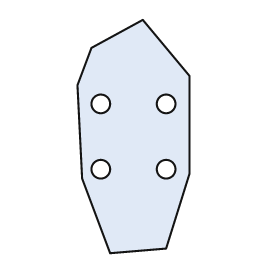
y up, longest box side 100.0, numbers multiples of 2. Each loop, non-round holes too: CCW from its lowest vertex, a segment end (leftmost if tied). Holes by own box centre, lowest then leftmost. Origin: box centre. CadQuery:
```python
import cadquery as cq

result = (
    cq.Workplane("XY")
    .moveTo(-10.0, -50.0)
    .lineTo(14.0, -48.0)
    .lineTo(24.0, -16.0)
    .lineTo(24.0, 26.0)
    .lineTo(4.0, 50.0)
    .lineTo(-18.0, 38.0)
    .lineTo(-24.0, 22.0)
    .lineTo(-22.0, -18.0)
    .close()
    .moveTo(-14.0, -14.0)
    .circle(4.0)
    .moveTo(14.0, -14.0)
    .circle(4.0)
    .moveTo(-14.0, 14.0)
    .circle(4.0)
    .moveTo(14.0, 14.0)
    .circle(4.0)
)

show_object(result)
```